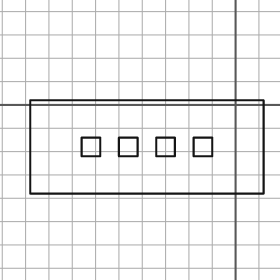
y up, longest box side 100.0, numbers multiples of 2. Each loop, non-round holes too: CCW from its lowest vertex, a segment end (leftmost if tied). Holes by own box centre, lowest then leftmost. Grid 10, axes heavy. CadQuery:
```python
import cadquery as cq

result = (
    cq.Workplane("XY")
    .moveTo(-88.0, -38.0)
    .lineTo(12.0, -38.0)
    .lineTo(12.0, 2.0)
    .lineTo(-88.0, 2.0)
    .close()
    .moveTo(-66.0, -22.0)
    .lineTo(-58.0, -22.0)
    .lineTo(-58.0, -14.0)
    .lineTo(-66.0, -14.0)
    .close()
    .moveTo(-50.0, -22.0)
    .lineTo(-42.0, -22.0)
    .lineTo(-42.0, -14.0)
    .lineTo(-50.0, -14.0)
    .close()
    .moveTo(-34.0, -22.0)
    .lineTo(-26.0, -22.0)
    .lineTo(-26.0, -14.0)
    .lineTo(-34.0, -14.0)
    .close()
    .moveTo(-18.0, -22.0)
    .lineTo(-10.0, -22.0)
    .lineTo(-10.0, -14.0)
    .lineTo(-18.0, -14.0)
    .close()
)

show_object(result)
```